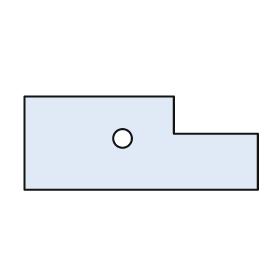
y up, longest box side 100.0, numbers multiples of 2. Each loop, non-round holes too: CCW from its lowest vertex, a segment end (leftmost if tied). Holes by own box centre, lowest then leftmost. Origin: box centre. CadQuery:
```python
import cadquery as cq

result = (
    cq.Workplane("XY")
    .moveTo(-50.0, -20.0)
    .lineTo(50.0, -20.0)
    .lineTo(50.0, 4.0)
    .lineTo(14.0, 4.0)
    .lineTo(14.0, 20.0)
    .lineTo(-50.0, 20.0)
    .close()
    .moveTo(-8.0, 2.0)
    .circle(4.0)
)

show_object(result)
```